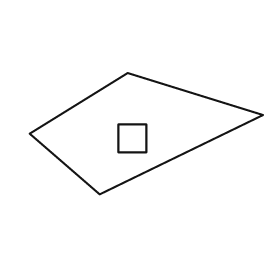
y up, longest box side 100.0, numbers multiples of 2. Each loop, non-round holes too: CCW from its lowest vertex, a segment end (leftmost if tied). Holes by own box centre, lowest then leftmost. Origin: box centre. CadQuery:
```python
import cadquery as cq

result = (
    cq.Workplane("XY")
    .moveTo(-20.0, -26.0)
    .lineTo(50.0, 8.0)
    .lineTo(-8.0, 26.0)
    .lineTo(-50.0, 0.0)
    .close()
    .moveTo(-12.0, -8.0)
    .lineTo(0.0, -8.0)
    .lineTo(0.0, 4.0)
    .lineTo(-12.0, 4.0)
    .close()
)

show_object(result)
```